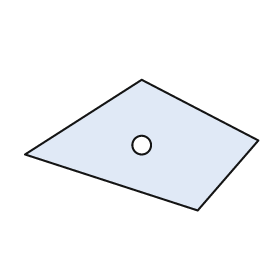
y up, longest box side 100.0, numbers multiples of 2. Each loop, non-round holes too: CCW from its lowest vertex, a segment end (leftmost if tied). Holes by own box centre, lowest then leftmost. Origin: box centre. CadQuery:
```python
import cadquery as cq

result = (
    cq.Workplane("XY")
    .moveTo(24.0, -28.0)
    .lineTo(50.0, 2.0)
    .lineTo(0.0, 28.0)
    .lineTo(-50.0, -4.0)
    .close()
    .moveTo(0.0, 0.0)
    .circle(4.0)
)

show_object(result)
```